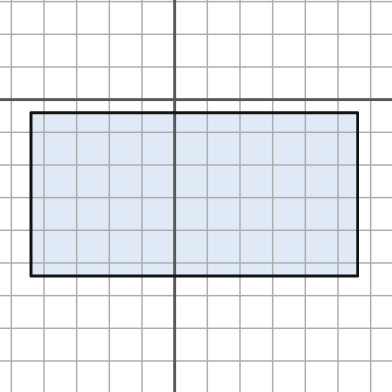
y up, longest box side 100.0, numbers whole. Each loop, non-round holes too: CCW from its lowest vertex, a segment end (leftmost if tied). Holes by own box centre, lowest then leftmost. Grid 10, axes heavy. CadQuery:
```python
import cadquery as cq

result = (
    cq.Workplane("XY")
    .moveTo(-44.0, -54.0)
    .lineTo(56.0, -54.0)
    .lineTo(56.0, -4.0)
    .lineTo(-44.0, -4.0)
    .close()
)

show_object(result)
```